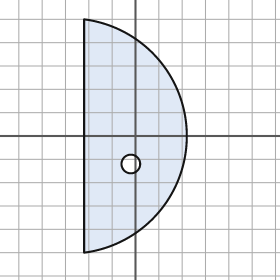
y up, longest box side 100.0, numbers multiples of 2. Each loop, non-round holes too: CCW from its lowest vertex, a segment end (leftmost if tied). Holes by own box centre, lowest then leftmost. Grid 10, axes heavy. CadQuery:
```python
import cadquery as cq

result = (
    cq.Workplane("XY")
    .moveTo(-22.0, -50.0)
    .threePointArc((22.0, 0.0), (-22.0, 50.0))
    .close()
    .moveTo(-2.0, -12.0)
    .circle(4.0)
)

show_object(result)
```